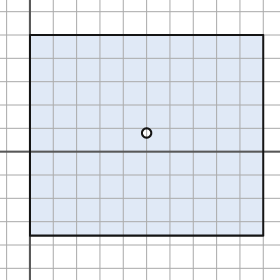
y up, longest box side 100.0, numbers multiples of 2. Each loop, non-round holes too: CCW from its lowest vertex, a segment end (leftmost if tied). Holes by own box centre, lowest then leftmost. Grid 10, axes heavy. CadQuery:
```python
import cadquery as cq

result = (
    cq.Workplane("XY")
    .moveTo(0.0, -36.0)
    .lineTo(100.0, -36.0)
    .lineTo(100.0, 50.0)
    .lineTo(0.0, 50.0)
    .close()
    .moveTo(50.0, 8.0)
    .circle(2.0)
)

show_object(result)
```